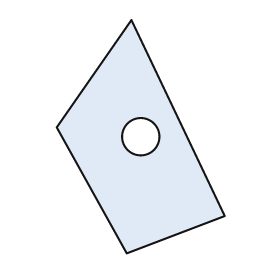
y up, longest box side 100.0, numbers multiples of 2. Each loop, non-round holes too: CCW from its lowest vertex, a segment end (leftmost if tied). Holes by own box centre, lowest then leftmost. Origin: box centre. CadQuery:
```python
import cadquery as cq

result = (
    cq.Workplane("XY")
    .moveTo(-6.0, -50.0)
    .lineTo(36.0, -34.0)
    .lineTo(-4.0, 50.0)
    .lineTo(-36.0, 4.0)
    .close()
    .moveTo(0.0, 0.0)
    .circle(8.0)
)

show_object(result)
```